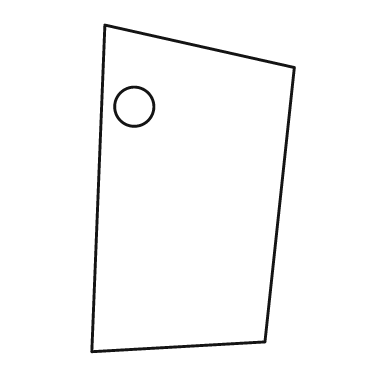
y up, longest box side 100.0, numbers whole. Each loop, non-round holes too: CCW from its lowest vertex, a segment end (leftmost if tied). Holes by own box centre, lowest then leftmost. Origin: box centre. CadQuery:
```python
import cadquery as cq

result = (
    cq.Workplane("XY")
    .moveTo(-31.0, -50.0)
    .lineTo(22.0, -47.0)
    .lineTo(31.0, 37.0)
    .lineTo(-27.0, 50.0)
    .close()
    .moveTo(-18.0, 25.0)
    .circle(6.0)
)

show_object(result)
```